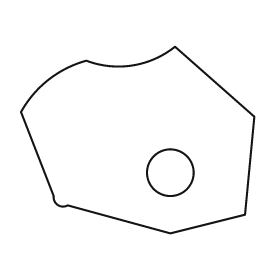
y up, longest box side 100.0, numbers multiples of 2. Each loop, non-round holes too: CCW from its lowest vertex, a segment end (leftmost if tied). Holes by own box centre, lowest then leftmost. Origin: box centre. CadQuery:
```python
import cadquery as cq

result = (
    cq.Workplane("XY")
    .moveTo(14.0, -40.0)
    .lineTo(46.0, -32.0)
    .lineTo(50.0, 10.0)
    .lineTo(16.0, 40.0)
    .threePointArc((-2.0, 32.0), (-22.0, 34.0))
    .threePointArc((-38.0, 26.0), (-50.0, 12.0))
    .lineTo(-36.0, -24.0)
    .threePointArc((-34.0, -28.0), (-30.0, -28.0))
    .close()
    .moveTo(14.0, -14.0)
    .circle(10.0)
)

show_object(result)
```